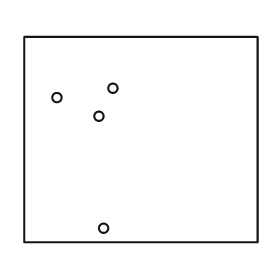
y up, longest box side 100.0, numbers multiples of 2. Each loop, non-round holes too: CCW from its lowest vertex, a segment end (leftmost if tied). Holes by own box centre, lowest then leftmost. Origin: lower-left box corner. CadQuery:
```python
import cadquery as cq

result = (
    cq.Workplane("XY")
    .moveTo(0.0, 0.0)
    .lineTo(100.0, 0.0)
    .lineTo(100.0, 88.0)
    .lineTo(0.0, 88.0)
    .close()
    .moveTo(34.0, 6.0)
    .circle(2.0)
    .moveTo(32.0, 54.0)
    .circle(2.0)
    .moveTo(14.0, 62.0)
    .circle(2.0)
    .moveTo(38.0, 66.0)
    .circle(2.0)
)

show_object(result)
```